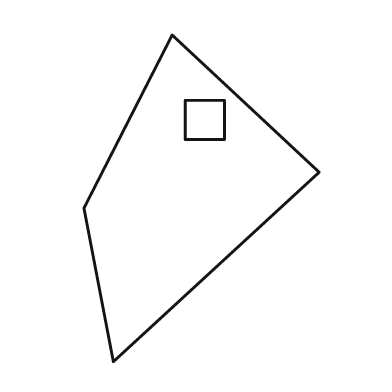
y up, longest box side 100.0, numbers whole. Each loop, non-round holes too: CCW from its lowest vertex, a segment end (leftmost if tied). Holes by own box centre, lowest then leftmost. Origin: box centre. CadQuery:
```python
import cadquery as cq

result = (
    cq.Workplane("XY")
    .moveTo(-27.0, -50.0)
    .lineTo(36.0, 8.0)
    .lineTo(-9.0, 50.0)
    .lineTo(-36.0, -3.0)
    .close()
    .moveTo(-5.0, 18.0)
    .lineTo(7.0, 18.0)
    .lineTo(7.0, 30.0)
    .lineTo(-5.0, 30.0)
    .close()
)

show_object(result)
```